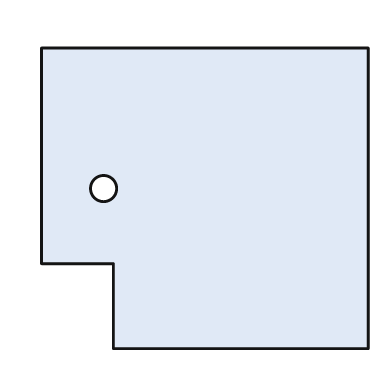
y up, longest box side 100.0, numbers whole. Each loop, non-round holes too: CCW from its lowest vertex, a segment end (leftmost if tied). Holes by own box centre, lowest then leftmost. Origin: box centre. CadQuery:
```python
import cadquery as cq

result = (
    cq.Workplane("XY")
    .moveTo(-28.0, -46.0)
    .lineTo(50.0, -46.0)
    .lineTo(50.0, 46.0)
    .lineTo(-50.0, 46.0)
    .lineTo(-50.0, -20.0)
    .lineTo(-28.0, -20.0)
    .close()
    .moveTo(-31.0, 3.0)
    .circle(4.0)
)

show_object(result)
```